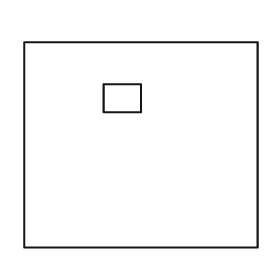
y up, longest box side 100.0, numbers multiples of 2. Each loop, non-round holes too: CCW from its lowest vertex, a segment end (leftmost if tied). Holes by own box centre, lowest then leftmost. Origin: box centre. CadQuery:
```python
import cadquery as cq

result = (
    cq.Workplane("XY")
    .moveTo(-50.0, -44.0)
    .lineTo(50.0, -44.0)
    .lineTo(50.0, 44.0)
    .lineTo(-50.0, 44.0)
    .close()
    .moveTo(-16.0, 14.0)
    .lineTo(0.0, 14.0)
    .lineTo(0.0, 26.0)
    .lineTo(-16.0, 26.0)
    .close()
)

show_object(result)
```